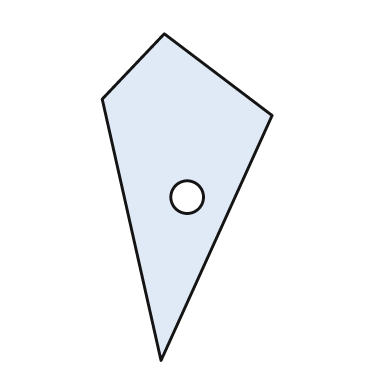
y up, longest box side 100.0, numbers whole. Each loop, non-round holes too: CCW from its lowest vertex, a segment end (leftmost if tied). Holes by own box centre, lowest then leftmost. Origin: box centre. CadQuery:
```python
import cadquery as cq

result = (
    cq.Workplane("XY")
    .moveTo(-8.0, -50.0)
    .lineTo(26.0, 25.0)
    .lineTo(-7.0, 50.0)
    .lineTo(-26.0, 30.0)
    .close()
    .moveTo(0.0, 0.0)
    .circle(5.0)
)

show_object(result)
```